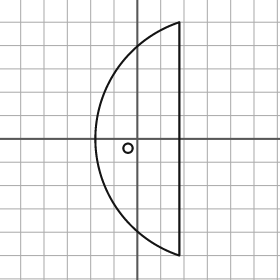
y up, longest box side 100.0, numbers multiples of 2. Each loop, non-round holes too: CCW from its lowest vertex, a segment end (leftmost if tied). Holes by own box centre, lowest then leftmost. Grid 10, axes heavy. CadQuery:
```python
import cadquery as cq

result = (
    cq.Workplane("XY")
    .moveTo(18.0, -50.0)
    .lineTo(18.0, 50.0)
    .threePointArc((-18.0, 0.0), (18.0, -50.0))
    .close()
    .moveTo(-4.0, -4.0)
    .circle(2.0)
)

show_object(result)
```